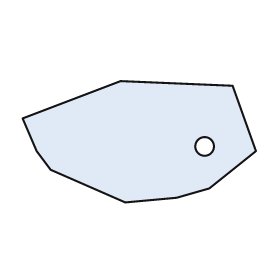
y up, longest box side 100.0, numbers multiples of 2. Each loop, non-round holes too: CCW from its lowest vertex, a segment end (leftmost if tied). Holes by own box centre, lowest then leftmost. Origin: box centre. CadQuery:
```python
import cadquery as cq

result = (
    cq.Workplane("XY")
    .moveTo(-6.0, -26.0)
    .lineTo(16.0, -24.0)
    .lineTo(30.0, -20.0)
    .lineTo(50.0, -4.0)
    .lineTo(40.0, 24.0)
    .lineTo(-8.0, 26.0)
    .lineTo(-50.0, 10.0)
    .lineTo(-44.0, -4.0)
    .lineTo(-38.0, -12.0)
    .close()
    .moveTo(28.0, -2.0)
    .circle(4.0)
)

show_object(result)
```